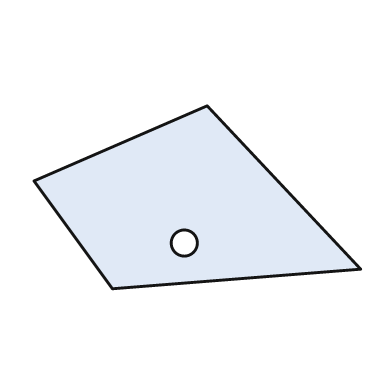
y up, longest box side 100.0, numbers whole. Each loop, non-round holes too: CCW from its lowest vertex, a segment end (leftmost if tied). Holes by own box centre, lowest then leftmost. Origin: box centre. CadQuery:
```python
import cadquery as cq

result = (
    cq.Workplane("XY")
    .moveTo(-26.0, -28.0)
    .lineTo(50.0, -22.0)
    .lineTo(3.0, 28.0)
    .lineTo(-50.0, 5.0)
    .close()
    .moveTo(-4.0, -14.0)
    .circle(4.0)
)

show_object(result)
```